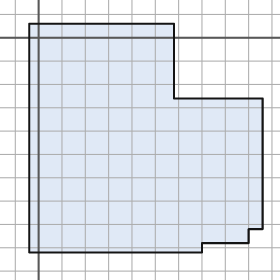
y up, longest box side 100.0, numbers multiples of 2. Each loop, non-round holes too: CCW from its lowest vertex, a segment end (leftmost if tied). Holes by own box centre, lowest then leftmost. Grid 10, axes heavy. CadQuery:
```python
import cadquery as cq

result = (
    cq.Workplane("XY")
    .moveTo(-4.0, -92.0)
    .lineTo(70.0, -92.0)
    .lineTo(70.0, -88.0)
    .lineTo(90.0, -88.0)
    .lineTo(90.0, -82.0)
    .lineTo(96.0, -82.0)
    .lineTo(96.0, -26.0)
    .lineTo(58.0, -26.0)
    .lineTo(58.0, 6.0)
    .lineTo(-4.0, 6.0)
    .close()
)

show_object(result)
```